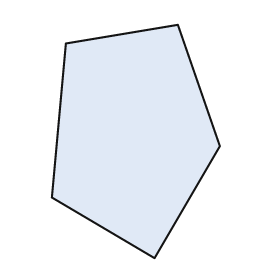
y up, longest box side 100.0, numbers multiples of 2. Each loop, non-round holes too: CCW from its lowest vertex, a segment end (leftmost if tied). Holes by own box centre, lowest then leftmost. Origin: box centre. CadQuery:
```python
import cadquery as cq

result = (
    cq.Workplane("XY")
    .moveTo(8.0, -50.0)
    .lineTo(36.0, -2.0)
    .lineTo(18.0, 50.0)
    .lineTo(-30.0, 42.0)
    .lineTo(-36.0, -24.0)
    .close()
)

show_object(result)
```